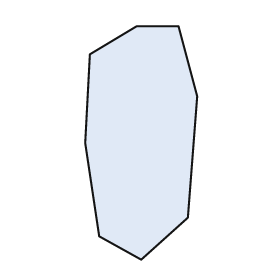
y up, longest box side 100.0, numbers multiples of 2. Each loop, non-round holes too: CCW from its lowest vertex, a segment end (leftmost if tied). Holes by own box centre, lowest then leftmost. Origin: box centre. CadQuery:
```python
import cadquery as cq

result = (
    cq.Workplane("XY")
    .moveTo(0.0, -50.0)
    .lineTo(20.0, -32.0)
    .lineTo(24.0, 20.0)
    .lineTo(16.0, 50.0)
    .lineTo(-2.0, 50.0)
    .lineTo(-22.0, 38.0)
    .lineTo(-24.0, 0.0)
    .lineTo(-18.0, -40.0)
    .close()
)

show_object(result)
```